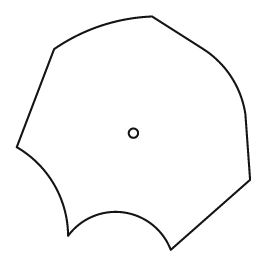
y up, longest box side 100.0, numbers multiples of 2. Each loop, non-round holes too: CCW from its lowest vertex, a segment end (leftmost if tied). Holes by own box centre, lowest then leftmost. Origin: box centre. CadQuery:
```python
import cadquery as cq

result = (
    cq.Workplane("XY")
    .moveTo(16.0, -50.0)
    .lineTo(50.0, -20.0)
    .lineTo(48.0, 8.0)
    .threePointArc((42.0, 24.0), (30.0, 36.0))
    .lineTo(8.0, 50.0)
    .threePointArc((-14.0, 46.0), (-34.0, 36.0))
    .lineTo(-50.0, -6.0)
    .threePointArc((-34.0, -22.0), (-28.0, -44.0))
    .threePointArc((-4.0, -34.0), (16.0, -50.0))
    .close()
    .moveTo(0.0, 0.0)
    .circle(2.0)
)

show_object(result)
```